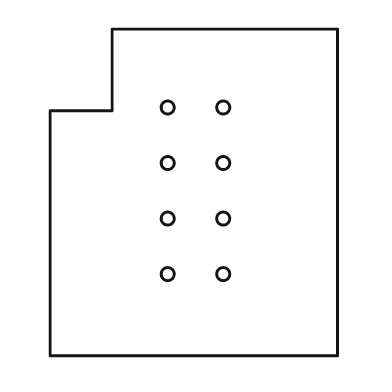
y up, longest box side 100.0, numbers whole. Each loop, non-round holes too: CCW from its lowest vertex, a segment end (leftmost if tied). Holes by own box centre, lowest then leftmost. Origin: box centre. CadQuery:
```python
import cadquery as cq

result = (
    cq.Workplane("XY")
    .moveTo(-44.0, -50.0)
    .lineTo(44.0, -50.0)
    .lineTo(44.0, 50.0)
    .lineTo(-25.0, 50.0)
    .lineTo(-25.0, 25.0)
    .lineTo(-44.0, 25.0)
    .close()
    .moveTo(-8.0, -25.0)
    .circle(2.0)
    .moveTo(9.0, -25.0)
    .circle(2.0)
    .moveTo(-8.0, -8.0)
    .circle(2.0)
    .moveTo(9.0, -8.0)
    .circle(2.0)
    .moveTo(-8.0, 9.0)
    .circle(2.0)
    .moveTo(9.0, 9.0)
    .circle(2.0)
    .moveTo(-8.0, 26.0)
    .circle(2.0)
    .moveTo(9.0, 26.0)
    .circle(2.0)
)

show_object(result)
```